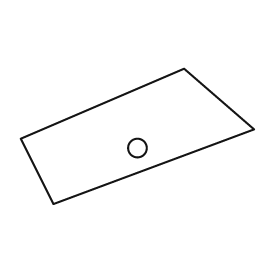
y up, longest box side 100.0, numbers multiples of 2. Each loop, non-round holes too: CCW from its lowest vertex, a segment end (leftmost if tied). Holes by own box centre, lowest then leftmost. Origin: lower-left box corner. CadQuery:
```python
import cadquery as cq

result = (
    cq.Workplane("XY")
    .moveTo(14.0, 0.0)
    .lineTo(100.0, 32.0)
    .lineTo(70.0, 58.0)
    .lineTo(0.0, 28.0)
    .close()
    .moveTo(50.0, 24.0)
    .circle(4.0)
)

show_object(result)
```